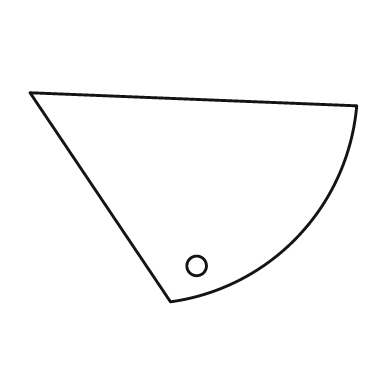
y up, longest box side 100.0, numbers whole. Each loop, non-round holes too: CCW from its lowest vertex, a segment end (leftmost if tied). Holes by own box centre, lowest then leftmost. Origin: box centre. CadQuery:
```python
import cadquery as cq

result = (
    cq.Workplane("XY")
    .moveTo(-7.0, -32.0)
    .threePointArc((32.0, -12.0), (50.0, 28.0))
    .lineTo(-50.0, 32.0)
    .close()
    .moveTo(1.0, -21.0)
    .circle(3.0)
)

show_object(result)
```